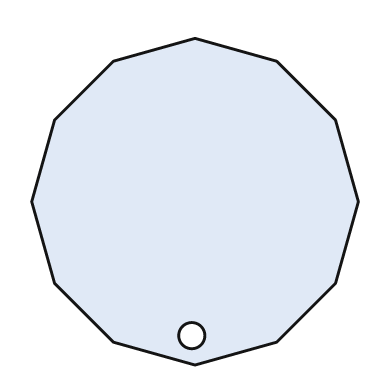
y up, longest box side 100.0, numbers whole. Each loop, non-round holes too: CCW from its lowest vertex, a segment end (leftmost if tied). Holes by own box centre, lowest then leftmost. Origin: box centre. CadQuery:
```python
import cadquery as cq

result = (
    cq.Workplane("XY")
    .moveTo(0.0, -50.0)
    .lineTo(25.0, -43.0)
    .lineTo(43.0, -25.0)
    .lineTo(50.0, 0.0)
    .lineTo(43.0, 25.0)
    .lineTo(25.0, 43.0)
    .lineTo(0.0, 50.0)
    .lineTo(-25.0, 43.0)
    .lineTo(-43.0, 25.0)
    .lineTo(-50.0, 0.0)
    .lineTo(-43.0, -25.0)
    .lineTo(-25.0, -43.0)
    .close()
    .moveTo(-1.0, -41.0)
    .circle(4.0)
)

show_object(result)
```